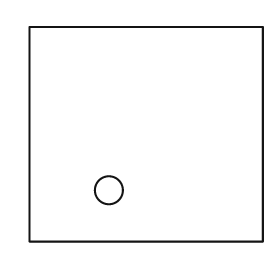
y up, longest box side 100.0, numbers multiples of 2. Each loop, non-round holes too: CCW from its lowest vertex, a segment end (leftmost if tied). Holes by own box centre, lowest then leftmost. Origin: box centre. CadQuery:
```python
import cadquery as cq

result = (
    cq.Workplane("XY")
    .moveTo(-50.0, -46.0)
    .lineTo(50.0, -46.0)
    .lineTo(50.0, 46.0)
    .lineTo(-50.0, 46.0)
    .close()
    .moveTo(-16.0, -24.0)
    .circle(6.0)
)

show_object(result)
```